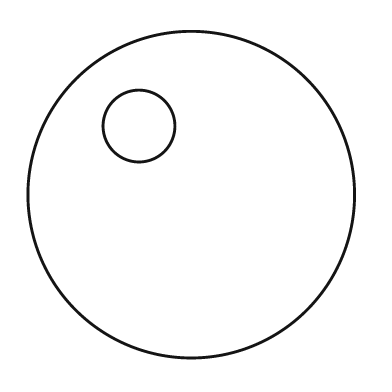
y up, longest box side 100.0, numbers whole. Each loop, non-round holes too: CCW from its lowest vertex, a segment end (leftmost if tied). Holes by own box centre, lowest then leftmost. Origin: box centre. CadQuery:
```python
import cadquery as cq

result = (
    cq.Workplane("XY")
    .moveTo(0.0, 0.0)
    .circle(50.0)
    .moveTo(-16.0, 21.0)
    .circle(11.0)
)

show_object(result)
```